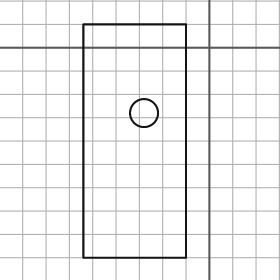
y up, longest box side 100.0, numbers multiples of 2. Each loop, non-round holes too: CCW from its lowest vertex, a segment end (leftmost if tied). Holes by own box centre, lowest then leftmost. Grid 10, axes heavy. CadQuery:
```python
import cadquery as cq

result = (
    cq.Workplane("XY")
    .moveTo(-54.0, -90.0)
    .lineTo(-10.0, -90.0)
    .lineTo(-10.0, 10.0)
    .lineTo(-54.0, 10.0)
    .close()
    .moveTo(-28.0, -28.0)
    .circle(6.0)
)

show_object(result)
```